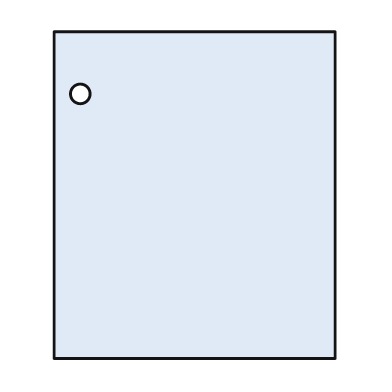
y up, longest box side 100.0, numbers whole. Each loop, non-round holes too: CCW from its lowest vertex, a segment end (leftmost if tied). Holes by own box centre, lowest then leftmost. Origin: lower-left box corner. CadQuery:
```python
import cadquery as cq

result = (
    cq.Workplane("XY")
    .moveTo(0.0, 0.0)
    .lineTo(86.0, 0.0)
    .lineTo(86.0, 100.0)
    .lineTo(0.0, 100.0)
    .close()
    .moveTo(8.0, 81.0)
    .circle(3.0)
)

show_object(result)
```